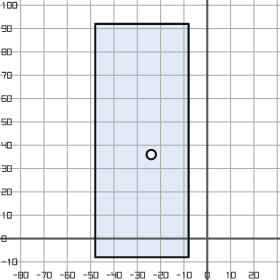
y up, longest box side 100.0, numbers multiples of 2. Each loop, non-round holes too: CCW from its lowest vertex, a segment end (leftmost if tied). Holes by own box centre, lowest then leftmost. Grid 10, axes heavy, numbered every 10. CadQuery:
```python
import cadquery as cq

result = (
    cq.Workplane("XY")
    .moveTo(-48.0, -8.0)
    .lineTo(-8.0, -8.0)
    .lineTo(-8.0, 92.0)
    .lineTo(-48.0, 92.0)
    .close()
    .moveTo(-24.0, 36.0)
    .circle(2.0)
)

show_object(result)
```